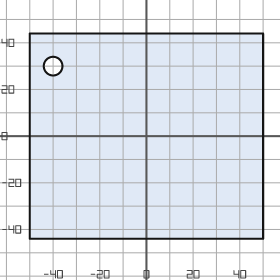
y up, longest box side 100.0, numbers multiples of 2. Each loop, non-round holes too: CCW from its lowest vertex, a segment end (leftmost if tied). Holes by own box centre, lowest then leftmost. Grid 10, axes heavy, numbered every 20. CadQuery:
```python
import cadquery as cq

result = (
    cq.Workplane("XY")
    .moveTo(-50.0, -44.0)
    .lineTo(50.0, -44.0)
    .lineTo(50.0, 44.0)
    .lineTo(-50.0, 44.0)
    .close()
    .moveTo(-40.0, 30.0)
    .circle(4.0)
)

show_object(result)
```